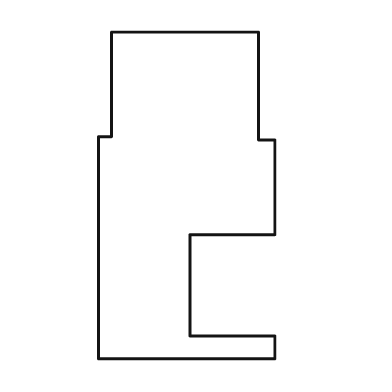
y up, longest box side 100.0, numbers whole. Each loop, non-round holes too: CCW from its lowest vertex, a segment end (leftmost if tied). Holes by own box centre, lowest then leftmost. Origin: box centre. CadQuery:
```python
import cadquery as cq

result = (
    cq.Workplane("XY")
    .moveTo(-27.0, -50.0)
    .lineTo(27.0, -50.0)
    .lineTo(27.0, -43.0)
    .lineTo(1.0, -43.0)
    .lineTo(1.0, -12.0)
    .lineTo(27.0, -12.0)
    .lineTo(27.0, 17.0)
    .lineTo(22.0, 17.0)
    .lineTo(22.0, 50.0)
    .lineTo(-23.0, 50.0)
    .lineTo(-23.0, 18.0)
    .lineTo(-27.0, 18.0)
    .close()
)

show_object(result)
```